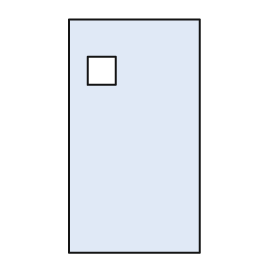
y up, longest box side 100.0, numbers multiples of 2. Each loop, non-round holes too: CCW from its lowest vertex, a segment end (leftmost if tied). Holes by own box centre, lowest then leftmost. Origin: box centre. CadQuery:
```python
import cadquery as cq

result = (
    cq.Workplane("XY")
    .moveTo(-28.0, -50.0)
    .lineTo(28.0, -50.0)
    .lineTo(28.0, 50.0)
    .lineTo(-28.0, 50.0)
    .close()
    .moveTo(-20.0, 22.0)
    .lineTo(-8.0, 22.0)
    .lineTo(-8.0, 34.0)
    .lineTo(-20.0, 34.0)
    .close()
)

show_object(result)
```